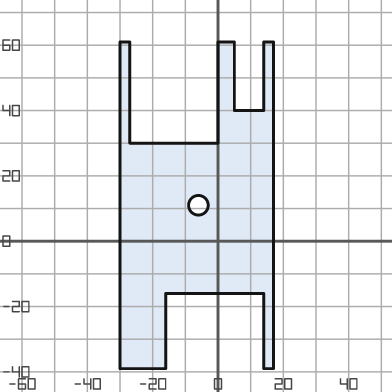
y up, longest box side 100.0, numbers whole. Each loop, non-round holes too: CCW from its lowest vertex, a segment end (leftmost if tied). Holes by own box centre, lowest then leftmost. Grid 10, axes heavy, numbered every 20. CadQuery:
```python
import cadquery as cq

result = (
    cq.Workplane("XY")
    .moveTo(-30.0, -39.0)
    .lineTo(-16.0, -39.0)
    .lineTo(-16.0, -16.0)
    .lineTo(14.0, -16.0)
    .lineTo(14.0, -39.0)
    .lineTo(17.0, -39.0)
    .lineTo(17.0, 61.0)
    .lineTo(14.0, 61.0)
    .lineTo(14.0, 40.0)
    .lineTo(5.0, 40.0)
    .lineTo(5.0, 61.0)
    .lineTo(0.0, 61.0)
    .lineTo(0.0, 30.0)
    .lineTo(-27.0, 30.0)
    .lineTo(-27.0, 61.0)
    .lineTo(-30.0, 61.0)
    .close()
    .moveTo(-6.0, 11.0)
    .circle(3.0)
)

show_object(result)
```